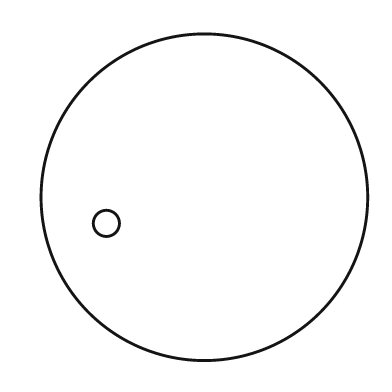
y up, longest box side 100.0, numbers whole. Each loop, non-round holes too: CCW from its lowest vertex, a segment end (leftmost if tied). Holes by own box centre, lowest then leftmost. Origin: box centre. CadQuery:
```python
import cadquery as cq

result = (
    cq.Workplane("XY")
    .moveTo(0.0, 0.0)
    .circle(50.0)
    .moveTo(-30.0, -8.0)
    .circle(4.0)
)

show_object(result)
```